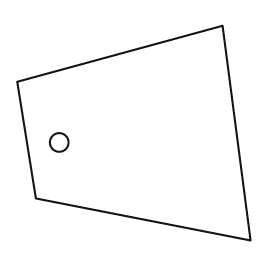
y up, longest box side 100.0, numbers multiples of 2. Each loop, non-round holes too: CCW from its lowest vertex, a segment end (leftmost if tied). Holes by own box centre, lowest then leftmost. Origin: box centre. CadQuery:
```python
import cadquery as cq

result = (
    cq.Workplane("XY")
    .moveTo(50.0, -46.0)
    .lineTo(38.0, 46.0)
    .lineTo(-50.0, 22.0)
    .lineTo(-42.0, -28.0)
    .close()
    .moveTo(-32.0, -4.0)
    .circle(4.0)
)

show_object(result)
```